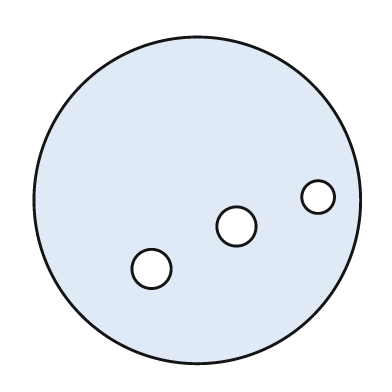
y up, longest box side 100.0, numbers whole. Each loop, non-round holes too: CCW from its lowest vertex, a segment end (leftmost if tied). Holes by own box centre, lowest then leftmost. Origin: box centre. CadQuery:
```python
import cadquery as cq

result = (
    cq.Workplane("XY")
    .moveTo(0.0, 0.0)
    .circle(50.0)
    .moveTo(-14.0, -21.0)
    .circle(6.0)
    .moveTo(12.0, -8.0)
    .circle(6.0)
    .moveTo(37.0, 1.0)
    .circle(5.0)
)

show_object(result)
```